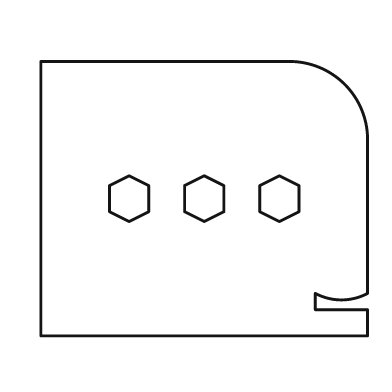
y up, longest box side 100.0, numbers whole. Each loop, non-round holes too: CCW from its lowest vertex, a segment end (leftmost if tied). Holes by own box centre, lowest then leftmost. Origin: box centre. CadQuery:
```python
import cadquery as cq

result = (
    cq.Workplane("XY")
    .moveTo(-50.0, -42.0)
    .lineTo(50.0, -42.0)
    .lineTo(50.0, -34.0)
    .lineTo(34.0, -34.0)
    .lineTo(34.0, -29.0)
    .threePointArc((42.0, -31.0), (50.0, -29.0))
    .lineTo(50.0, 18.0)
    .threePointArc((43.0, 35.0), (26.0, 42.0))
    .lineTo(-50.0, 42.0)
    .close()
    .moveTo(-23.0, -7.0)
    .lineTo(-17.0, -4.0)
    .lineTo(-17.0, 4.0)
    .lineTo(-23.0, 7.0)
    .lineTo(-29.0, 4.0)
    .lineTo(-29.0, -4.0)
    .close()
    .moveTo(0.0, -7.0)
    .lineTo(6.0, -4.0)
    .lineTo(6.0, 4.0)
    .lineTo(0.0, 7.0)
    .lineTo(-6.0, 4.0)
    .lineTo(-6.0, -4.0)
    .close()
    .moveTo(23.0, -7.0)
    .lineTo(29.0, -4.0)
    .lineTo(29.0, 4.0)
    .lineTo(23.0, 7.0)
    .lineTo(17.0, 4.0)
    .lineTo(17.0, -4.0)
    .close()
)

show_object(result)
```